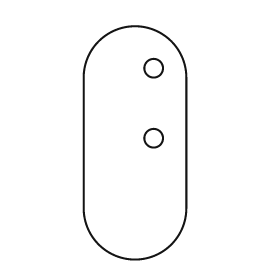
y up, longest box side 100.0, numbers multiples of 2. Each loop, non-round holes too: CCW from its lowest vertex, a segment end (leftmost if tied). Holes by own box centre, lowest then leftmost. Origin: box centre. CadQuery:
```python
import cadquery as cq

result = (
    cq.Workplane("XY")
    .moveTo(-22.0, -28.0)
    .threePointArc((0.0, -50.0), (22.0, -28.0))
    .lineTo(22.0, 28.0)
    .threePointArc((0.0, 50.0), (-22.0, 28.0))
    .close()
    .moveTo(8.0, 2.0)
    .circle(4.0)
    .moveTo(8.0, 32.0)
    .circle(4.0)
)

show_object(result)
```